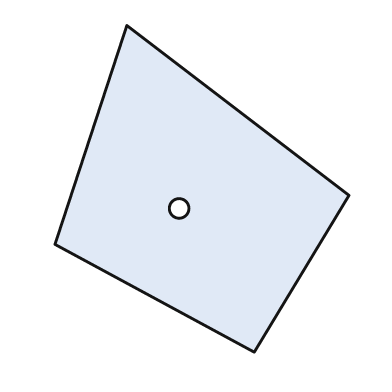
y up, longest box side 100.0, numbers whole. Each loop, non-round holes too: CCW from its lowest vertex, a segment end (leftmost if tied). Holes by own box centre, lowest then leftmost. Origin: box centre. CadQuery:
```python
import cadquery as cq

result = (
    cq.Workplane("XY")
    .moveTo(16.0, -50.0)
    .lineTo(45.0, -2.0)
    .lineTo(-23.0, 50.0)
    .lineTo(-45.0, -17.0)
    .close()
    .moveTo(-7.0, -6.0)
    .circle(3.0)
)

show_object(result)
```